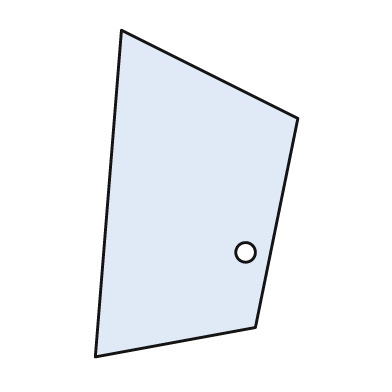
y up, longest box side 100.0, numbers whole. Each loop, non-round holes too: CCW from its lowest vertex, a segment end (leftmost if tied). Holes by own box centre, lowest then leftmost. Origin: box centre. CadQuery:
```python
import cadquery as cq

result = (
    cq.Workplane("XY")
    .moveTo(-31.0, -50.0)
    .lineTo(18.0, -41.0)
    .lineTo(31.0, 23.0)
    .lineTo(-23.0, 50.0)
    .close()
    .moveTo(15.0, -18.0)
    .circle(3.0)
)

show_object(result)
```